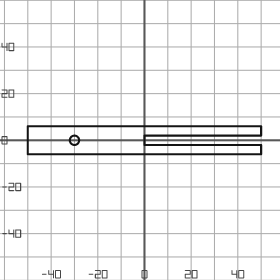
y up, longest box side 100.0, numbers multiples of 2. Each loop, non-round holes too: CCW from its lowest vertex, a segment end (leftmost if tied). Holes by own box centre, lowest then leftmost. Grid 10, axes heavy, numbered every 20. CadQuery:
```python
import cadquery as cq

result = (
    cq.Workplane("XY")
    .moveTo(-50.0, -6.0)
    .lineTo(50.0, -6.0)
    .lineTo(50.0, -2.0)
    .lineTo(0.0, -2.0)
    .lineTo(0.0, 2.0)
    .lineTo(50.0, 2.0)
    .lineTo(50.0, 6.0)
    .lineTo(-50.0, 6.0)
    .close()
    .moveTo(-30.0, 0.0)
    .circle(2.0)
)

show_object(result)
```